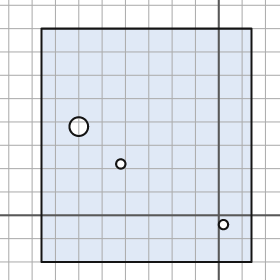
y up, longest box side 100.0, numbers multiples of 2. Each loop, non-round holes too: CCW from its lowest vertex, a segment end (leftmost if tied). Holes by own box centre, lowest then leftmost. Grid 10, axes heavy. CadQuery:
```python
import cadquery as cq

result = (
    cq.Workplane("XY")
    .moveTo(-76.0, -20.0)
    .lineTo(14.0, -20.0)
    .lineTo(14.0, 80.0)
    .lineTo(-76.0, 80.0)
    .close()
    .moveTo(2.0, -4.0)
    .circle(2.0)
    .moveTo(-42.0, 22.0)
    .circle(2.0)
    .moveTo(-60.0, 38.0)
    .circle(4.0)
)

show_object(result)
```